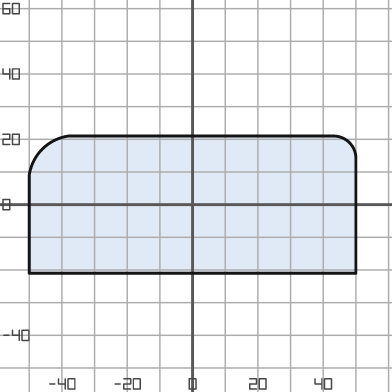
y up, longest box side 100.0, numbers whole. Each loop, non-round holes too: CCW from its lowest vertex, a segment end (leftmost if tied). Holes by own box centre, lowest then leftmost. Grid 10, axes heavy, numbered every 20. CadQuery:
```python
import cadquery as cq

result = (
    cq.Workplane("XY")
    .moveTo(-50.0, -21.0)
    .lineTo(50.0, -21.0)
    .lineTo(50.0, 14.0)
    .threePointArc((48.0, 19.0), (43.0, 21.0))
    .lineTo(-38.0, 21.0)
    .threePointArc((-46.0, 17.0), (-50.0, 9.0))
    .close()
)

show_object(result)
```